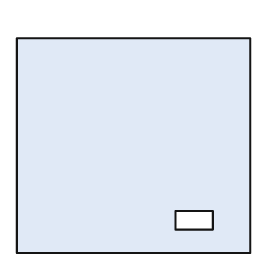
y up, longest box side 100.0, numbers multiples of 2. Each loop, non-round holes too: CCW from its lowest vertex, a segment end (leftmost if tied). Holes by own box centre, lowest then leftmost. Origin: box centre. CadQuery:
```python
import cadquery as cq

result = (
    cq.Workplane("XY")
    .moveTo(-50.0, -46.0)
    .lineTo(50.0, -46.0)
    .lineTo(50.0, 46.0)
    .lineTo(-50.0, 46.0)
    .close()
    .moveTo(18.0, -36.0)
    .lineTo(34.0, -36.0)
    .lineTo(34.0, -28.0)
    .lineTo(18.0, -28.0)
    .close()
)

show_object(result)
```